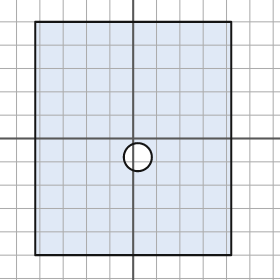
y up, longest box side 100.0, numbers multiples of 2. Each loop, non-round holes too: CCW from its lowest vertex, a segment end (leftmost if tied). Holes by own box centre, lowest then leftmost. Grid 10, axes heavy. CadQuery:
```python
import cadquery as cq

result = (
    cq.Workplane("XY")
    .moveTo(-42.0, -50.0)
    .lineTo(42.0, -50.0)
    .lineTo(42.0, 50.0)
    .lineTo(-42.0, 50.0)
    .close()
    .moveTo(2.0, -8.0)
    .circle(6.0)
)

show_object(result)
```